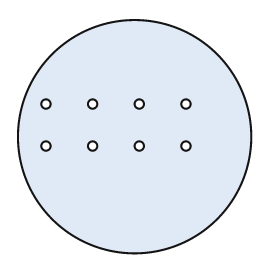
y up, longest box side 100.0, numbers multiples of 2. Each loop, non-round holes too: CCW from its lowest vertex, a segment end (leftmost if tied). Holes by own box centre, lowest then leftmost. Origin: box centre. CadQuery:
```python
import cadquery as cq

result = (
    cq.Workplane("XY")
    .moveTo(0.0, 0.0)
    .circle(50.0)
    .moveTo(-38.0, -4.0)
    .circle(2.0)
    .moveTo(-18.0, -4.0)
    .circle(2.0)
    .moveTo(2.0, -4.0)
    .circle(2.0)
    .moveTo(22.0, -4.0)
    .circle(2.0)
    .moveTo(-38.0, 14.0)
    .circle(2.0)
    .moveTo(-18.0, 14.0)
    .circle(2.0)
    .moveTo(2.0, 14.0)
    .circle(2.0)
    .moveTo(22.0, 14.0)
    .circle(2.0)
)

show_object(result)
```